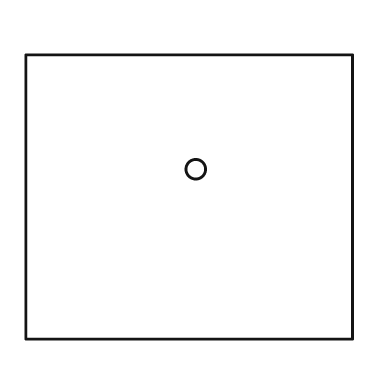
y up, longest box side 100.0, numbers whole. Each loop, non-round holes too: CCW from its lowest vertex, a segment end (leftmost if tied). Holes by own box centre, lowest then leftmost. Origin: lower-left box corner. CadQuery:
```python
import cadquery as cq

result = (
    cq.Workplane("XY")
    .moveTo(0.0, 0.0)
    .lineTo(100.0, 0.0)
    .lineTo(100.0, 87.0)
    .lineTo(0.0, 87.0)
    .close()
    .moveTo(52.0, 52.0)
    .circle(3.0)
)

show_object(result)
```